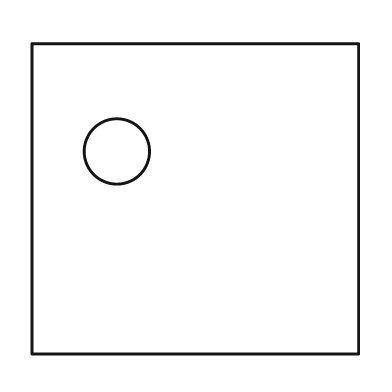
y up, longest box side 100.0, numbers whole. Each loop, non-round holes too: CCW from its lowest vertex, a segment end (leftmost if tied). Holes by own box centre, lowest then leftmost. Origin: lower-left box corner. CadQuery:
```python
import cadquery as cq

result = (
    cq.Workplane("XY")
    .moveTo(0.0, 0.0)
    .lineTo(100.0, 0.0)
    .lineTo(100.0, 95.0)
    .lineTo(0.0, 95.0)
    .close()
    .moveTo(26.0, 62.0)
    .circle(10.0)
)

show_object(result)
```